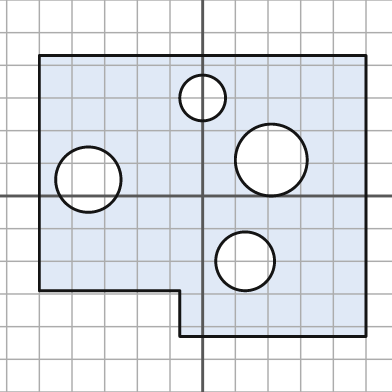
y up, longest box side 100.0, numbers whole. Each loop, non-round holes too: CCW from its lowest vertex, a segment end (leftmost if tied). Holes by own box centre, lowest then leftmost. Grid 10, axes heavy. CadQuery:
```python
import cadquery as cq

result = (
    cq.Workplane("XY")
    .moveTo(-7.0, -43.0)
    .lineTo(50.0, -43.0)
    .lineTo(50.0, 43.0)
    .lineTo(-50.0, 43.0)
    .lineTo(-50.0, -29.0)
    .lineTo(-7.0, -29.0)
    .close()
    .moveTo(13.0, -20.0)
    .circle(9.0)
    .moveTo(-35.0, 5.0)
    .circle(10.0)
    .moveTo(21.0, 11.0)
    .circle(11.0)
    .moveTo(0.0, 30.0)
    .circle(7.0)
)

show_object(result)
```